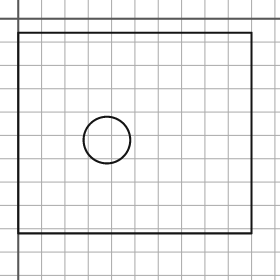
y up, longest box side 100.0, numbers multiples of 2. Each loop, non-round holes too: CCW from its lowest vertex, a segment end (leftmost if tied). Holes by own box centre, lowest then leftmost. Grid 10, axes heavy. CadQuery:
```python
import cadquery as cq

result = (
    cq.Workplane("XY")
    .moveTo(0.0, -92.0)
    .lineTo(100.0, -92.0)
    .lineTo(100.0, -6.0)
    .lineTo(0.0, -6.0)
    .close()
    .moveTo(38.0, -52.0)
    .circle(10.0)
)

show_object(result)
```